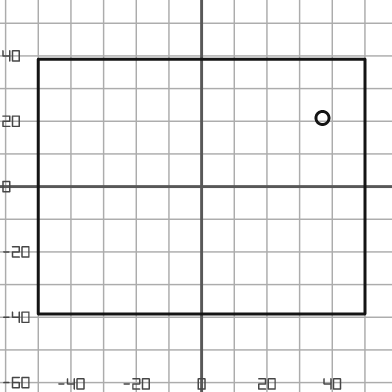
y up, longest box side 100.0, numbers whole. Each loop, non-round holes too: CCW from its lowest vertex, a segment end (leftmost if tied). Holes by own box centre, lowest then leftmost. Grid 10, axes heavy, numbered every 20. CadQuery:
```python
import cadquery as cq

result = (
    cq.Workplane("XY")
    .moveTo(-50.0, -39.0)
    .lineTo(50.0, -39.0)
    .lineTo(50.0, 39.0)
    .lineTo(-50.0, 39.0)
    .close()
    .moveTo(37.0, 21.0)
    .circle(2.0)
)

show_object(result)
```